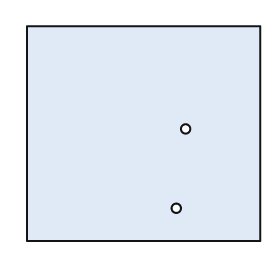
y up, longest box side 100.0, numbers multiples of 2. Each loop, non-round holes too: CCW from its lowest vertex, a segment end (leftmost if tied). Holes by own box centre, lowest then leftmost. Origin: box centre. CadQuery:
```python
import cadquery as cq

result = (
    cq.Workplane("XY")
    .moveTo(-50.0, -46.0)
    .lineTo(50.0, -46.0)
    .lineTo(50.0, 46.0)
    .lineTo(-50.0, 46.0)
    .close()
    .moveTo(14.0, -32.0)
    .circle(2.0)
    .moveTo(18.0, 2.0)
    .circle(2.0)
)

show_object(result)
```